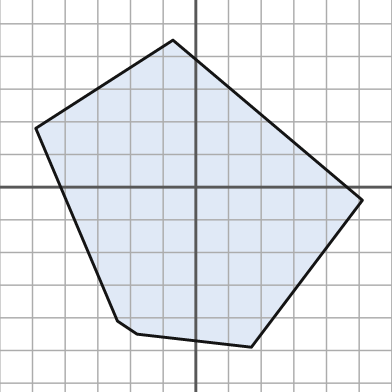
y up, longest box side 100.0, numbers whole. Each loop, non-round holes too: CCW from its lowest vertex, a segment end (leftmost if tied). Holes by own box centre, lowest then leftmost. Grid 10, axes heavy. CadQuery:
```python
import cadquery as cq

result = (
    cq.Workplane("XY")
    .moveTo(17.0, -49.0)
    .lineTo(51.0, -4.0)
    .lineTo(-7.0, 45.0)
    .lineTo(-49.0, 18.0)
    .lineTo(-24.0, -41.0)
    .lineTo(-18.0, -45.0)
    .close()
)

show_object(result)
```